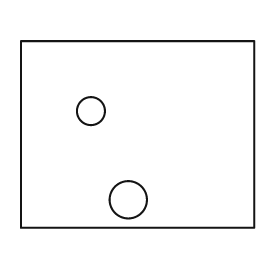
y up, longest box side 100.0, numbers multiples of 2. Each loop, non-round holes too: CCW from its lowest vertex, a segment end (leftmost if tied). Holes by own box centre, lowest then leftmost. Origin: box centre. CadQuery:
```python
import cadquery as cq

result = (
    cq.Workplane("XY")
    .moveTo(-50.0, -40.0)
    .lineTo(50.0, -40.0)
    .lineTo(50.0, 40.0)
    .lineTo(-50.0, 40.0)
    .close()
    .moveTo(-4.0, -28.0)
    .circle(8.0)
    .moveTo(-20.0, 10.0)
    .circle(6.0)
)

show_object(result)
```